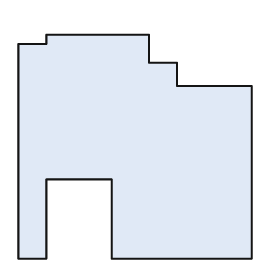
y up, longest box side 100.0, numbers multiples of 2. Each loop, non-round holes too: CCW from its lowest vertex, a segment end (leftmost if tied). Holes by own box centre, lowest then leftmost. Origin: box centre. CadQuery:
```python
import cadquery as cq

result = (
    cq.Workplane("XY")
    .moveTo(-50.0, -48.0)
    .lineTo(-38.0, -48.0)
    .lineTo(-38.0, -14.0)
    .lineTo(-10.0, -14.0)
    .lineTo(-10.0, -48.0)
    .lineTo(50.0, -48.0)
    .lineTo(50.0, 26.0)
    .lineTo(18.0, 26.0)
    .lineTo(18.0, 36.0)
    .lineTo(6.0, 36.0)
    .lineTo(6.0, 48.0)
    .lineTo(-38.0, 48.0)
    .lineTo(-38.0, 44.0)
    .lineTo(-50.0, 44.0)
    .close()
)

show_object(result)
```